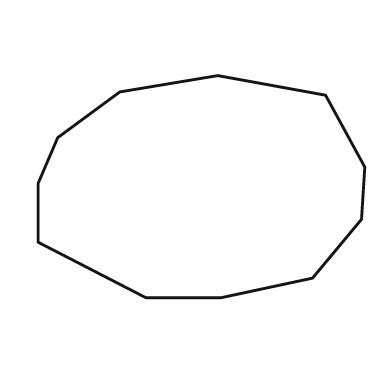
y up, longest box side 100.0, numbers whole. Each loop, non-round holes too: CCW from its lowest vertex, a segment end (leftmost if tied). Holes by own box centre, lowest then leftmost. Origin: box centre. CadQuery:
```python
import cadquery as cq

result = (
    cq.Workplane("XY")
    .moveTo(-17.0, -34.0)
    .lineTo(6.0, -34.0)
    .lineTo(34.0, -28.0)
    .lineTo(49.0, -10.0)
    .lineTo(50.0, 6.0)
    .lineTo(38.0, 28.0)
    .lineTo(5.0, 34.0)
    .lineTo(-25.0, 29.0)
    .lineTo(-44.0, 15.0)
    .lineTo(-50.0, 1.0)
    .lineTo(-50.0, -17.0)
    .close()
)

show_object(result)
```